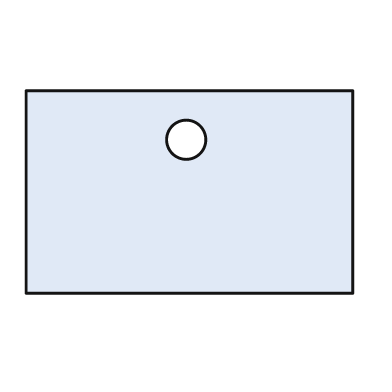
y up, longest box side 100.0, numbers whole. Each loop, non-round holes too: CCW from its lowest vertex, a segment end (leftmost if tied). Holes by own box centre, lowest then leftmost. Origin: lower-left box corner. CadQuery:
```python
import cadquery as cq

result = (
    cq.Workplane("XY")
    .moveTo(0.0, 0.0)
    .lineTo(100.0, 0.0)
    .lineTo(100.0, 62.0)
    .lineTo(0.0, 62.0)
    .close()
    .moveTo(49.0, 47.0)
    .circle(6.0)
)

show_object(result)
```